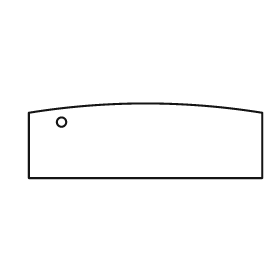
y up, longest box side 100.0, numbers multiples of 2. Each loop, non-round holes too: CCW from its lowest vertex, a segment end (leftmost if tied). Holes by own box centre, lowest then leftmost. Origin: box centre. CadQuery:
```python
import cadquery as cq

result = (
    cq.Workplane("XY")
    .moveTo(-50.0, -16.0)
    .lineTo(50.0, -16.0)
    .lineTo(50.0, 12.0)
    .threePointArc((0.0, 16.0), (-50.0, 12.0))
    .close()
    .moveTo(-36.0, 8.0)
    .circle(2.0)
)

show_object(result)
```